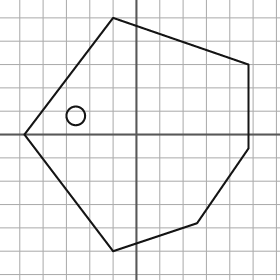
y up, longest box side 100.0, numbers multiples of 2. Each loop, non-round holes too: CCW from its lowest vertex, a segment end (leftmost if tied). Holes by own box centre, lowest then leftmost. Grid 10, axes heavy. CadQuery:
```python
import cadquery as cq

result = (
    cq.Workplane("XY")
    .moveTo(-10.0, -50.0)
    .lineTo(26.0, -38.0)
    .lineTo(48.0, -6.0)
    .lineTo(48.0, 30.0)
    .lineTo(-10.0, 50.0)
    .lineTo(-48.0, 0.0)
    .close()
    .moveTo(-26.0, 8.0)
    .circle(4.0)
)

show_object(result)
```